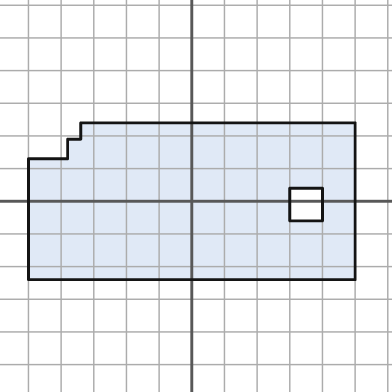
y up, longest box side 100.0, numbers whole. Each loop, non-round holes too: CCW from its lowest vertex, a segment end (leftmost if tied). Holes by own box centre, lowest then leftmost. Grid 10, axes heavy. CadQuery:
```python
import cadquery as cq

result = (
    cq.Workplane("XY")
    .moveTo(-50.0, -24.0)
    .lineTo(50.0, -24.0)
    .lineTo(50.0, 24.0)
    .lineTo(-34.0, 24.0)
    .lineTo(-34.0, 19.0)
    .lineTo(-38.0, 19.0)
    .lineTo(-38.0, 13.0)
    .lineTo(-50.0, 13.0)
    .close()
    .moveTo(30.0, -6.0)
    .lineTo(40.0, -6.0)
    .lineTo(40.0, 4.0)
    .lineTo(30.0, 4.0)
    .close()
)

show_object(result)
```